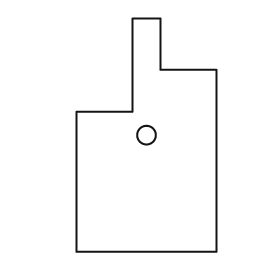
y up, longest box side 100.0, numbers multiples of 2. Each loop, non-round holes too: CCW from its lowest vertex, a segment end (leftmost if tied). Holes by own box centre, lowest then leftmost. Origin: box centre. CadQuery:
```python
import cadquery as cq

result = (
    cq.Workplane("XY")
    .moveTo(-30.0, -50.0)
    .lineTo(30.0, -50.0)
    .lineTo(30.0, 28.0)
    .lineTo(6.0, 28.0)
    .lineTo(6.0, 50.0)
    .lineTo(-6.0, 50.0)
    .lineTo(-6.0, 10.0)
    .lineTo(-30.0, 10.0)
    .close()
    .moveTo(0.0, 0.0)
    .circle(4.0)
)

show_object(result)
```